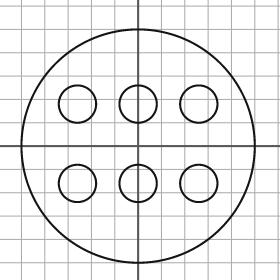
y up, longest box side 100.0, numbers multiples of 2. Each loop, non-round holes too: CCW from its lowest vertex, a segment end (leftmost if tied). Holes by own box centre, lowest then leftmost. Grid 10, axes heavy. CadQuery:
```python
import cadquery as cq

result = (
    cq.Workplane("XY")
    .moveTo(0.0, 0.0)
    .circle(50.0)
    .moveTo(-26.0, -16.0)
    .circle(8.0)
    .moveTo(0.0, -16.0)
    .circle(8.0)
    .moveTo(26.0, -16.0)
    .circle(8.0)
    .moveTo(-26.0, 18.0)
    .circle(8.0)
    .moveTo(0.0, 18.0)
    .circle(8.0)
    .moveTo(26.0, 18.0)
    .circle(8.0)
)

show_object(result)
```